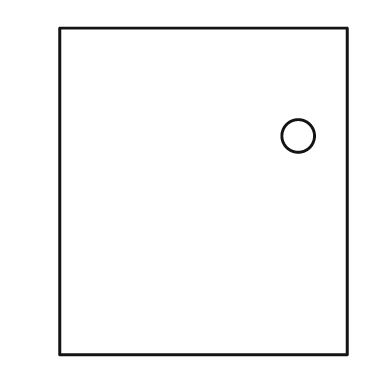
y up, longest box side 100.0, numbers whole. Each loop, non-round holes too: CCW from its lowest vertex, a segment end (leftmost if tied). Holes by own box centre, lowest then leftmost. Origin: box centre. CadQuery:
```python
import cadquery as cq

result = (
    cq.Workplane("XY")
    .moveTo(-44.0, -50.0)
    .lineTo(44.0, -50.0)
    .lineTo(44.0, 50.0)
    .lineTo(-44.0, 50.0)
    .close()
    .moveTo(29.0, 17.0)
    .circle(5.0)
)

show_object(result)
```